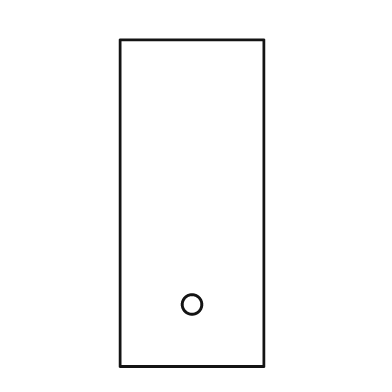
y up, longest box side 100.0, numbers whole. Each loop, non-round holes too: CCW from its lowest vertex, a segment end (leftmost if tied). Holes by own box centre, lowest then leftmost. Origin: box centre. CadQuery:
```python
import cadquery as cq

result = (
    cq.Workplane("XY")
    .moveTo(-22.0, -50.0)
    .lineTo(22.0, -50.0)
    .lineTo(22.0, 50.0)
    .lineTo(-22.0, 50.0)
    .close()
    .moveTo(0.0, -31.0)
    .circle(3.0)
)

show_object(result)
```